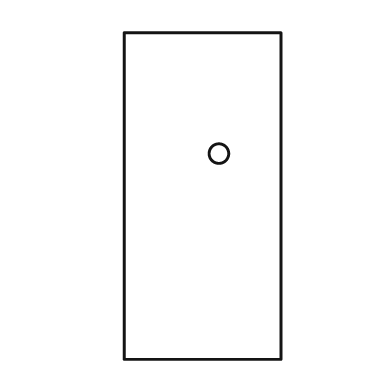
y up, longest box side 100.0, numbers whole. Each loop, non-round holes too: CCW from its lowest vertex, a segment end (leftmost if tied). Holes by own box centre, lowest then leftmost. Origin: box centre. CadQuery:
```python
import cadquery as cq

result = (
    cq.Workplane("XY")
    .moveTo(-24.0, -50.0)
    .lineTo(24.0, -50.0)
    .lineTo(24.0, 50.0)
    .lineTo(-24.0, 50.0)
    .close()
    .moveTo(5.0, 13.0)
    .circle(3.0)
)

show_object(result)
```